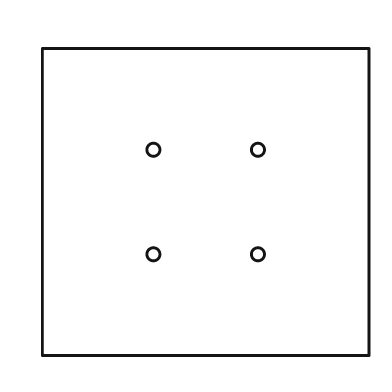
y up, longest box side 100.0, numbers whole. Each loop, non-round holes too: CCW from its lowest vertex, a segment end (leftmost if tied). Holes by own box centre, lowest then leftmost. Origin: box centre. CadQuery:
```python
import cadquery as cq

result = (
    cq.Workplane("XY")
    .moveTo(-50.0, -47.0)
    .lineTo(50.0, -47.0)
    .lineTo(50.0, 47.0)
    .lineTo(-50.0, 47.0)
    .close()
    .moveTo(-16.0, -16.0)
    .circle(2.0)
    .moveTo(16.0, -16.0)
    .circle(2.0)
    .moveTo(-16.0, 16.0)
    .circle(2.0)
    .moveTo(16.0, 16.0)
    .circle(2.0)
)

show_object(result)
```